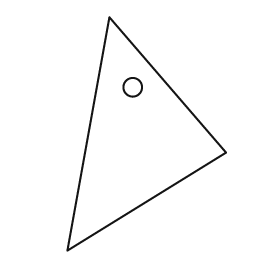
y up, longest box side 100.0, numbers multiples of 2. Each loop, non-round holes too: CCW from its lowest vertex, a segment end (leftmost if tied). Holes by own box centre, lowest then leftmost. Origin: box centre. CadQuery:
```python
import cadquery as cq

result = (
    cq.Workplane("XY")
    .moveTo(-34.0, -50.0)
    .lineTo(34.0, -8.0)
    .lineTo(-16.0, 50.0)
    .close()
    .moveTo(-6.0, 20.0)
    .circle(4.0)
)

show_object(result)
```